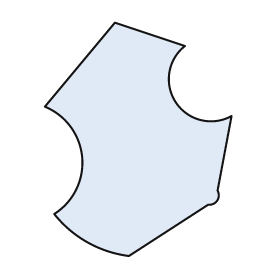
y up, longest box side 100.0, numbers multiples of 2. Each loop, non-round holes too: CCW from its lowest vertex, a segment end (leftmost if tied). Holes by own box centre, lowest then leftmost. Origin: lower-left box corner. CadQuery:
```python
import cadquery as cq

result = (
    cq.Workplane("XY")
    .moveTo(36.0, 0.0)
    .lineTo(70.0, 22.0)
    .threePointArc((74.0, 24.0), (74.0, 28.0))
    .lineTo(80.0, 60.0)
    .threePointArc((56.0, 66.0), (60.0, 90.0))
    .lineTo(30.0, 100.0)
    .lineTo(0.0, 64.0)
    .threePointArc((16.0, 42.0), (4.0, 18.0))
    .threePointArc((18.0, 6.0), (36.0, 0.0))
    .close()
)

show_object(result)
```